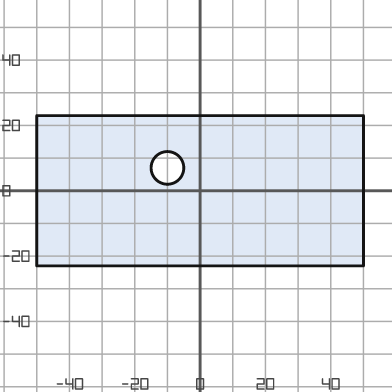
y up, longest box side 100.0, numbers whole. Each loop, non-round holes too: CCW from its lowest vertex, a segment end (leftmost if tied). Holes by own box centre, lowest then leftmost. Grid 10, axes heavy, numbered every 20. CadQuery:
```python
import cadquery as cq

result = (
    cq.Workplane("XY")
    .moveTo(-50.0, -23.0)
    .lineTo(50.0, -23.0)
    .lineTo(50.0, 23.0)
    .lineTo(-50.0, 23.0)
    .close()
    .moveTo(-10.0, 7.0)
    .circle(5.0)
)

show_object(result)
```